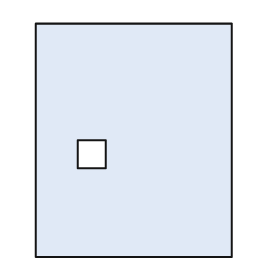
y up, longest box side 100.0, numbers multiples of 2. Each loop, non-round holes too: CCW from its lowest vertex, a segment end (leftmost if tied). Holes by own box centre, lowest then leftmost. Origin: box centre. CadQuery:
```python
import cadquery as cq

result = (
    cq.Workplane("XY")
    .moveTo(-42.0, -50.0)
    .lineTo(42.0, -50.0)
    .lineTo(42.0, 50.0)
    .lineTo(-42.0, 50.0)
    .close()
    .moveTo(-24.0, -12.0)
    .lineTo(-12.0, -12.0)
    .lineTo(-12.0, 0.0)
    .lineTo(-24.0, 0.0)
    .close()
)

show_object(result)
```